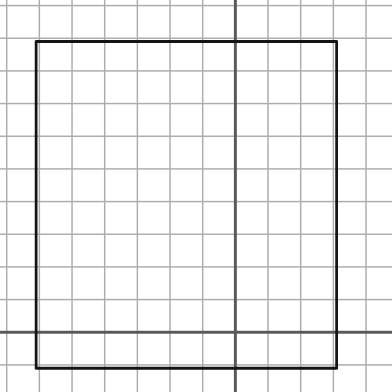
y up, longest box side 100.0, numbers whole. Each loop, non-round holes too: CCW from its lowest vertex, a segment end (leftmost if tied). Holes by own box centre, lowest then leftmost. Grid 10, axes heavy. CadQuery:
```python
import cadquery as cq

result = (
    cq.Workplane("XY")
    .moveTo(-61.0, -11.0)
    .lineTo(31.0, -11.0)
    .lineTo(31.0, 89.0)
    .lineTo(-61.0, 89.0)
    .close()
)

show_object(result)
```